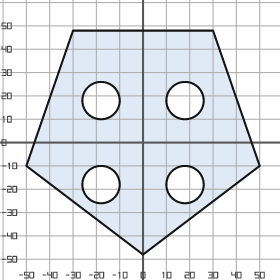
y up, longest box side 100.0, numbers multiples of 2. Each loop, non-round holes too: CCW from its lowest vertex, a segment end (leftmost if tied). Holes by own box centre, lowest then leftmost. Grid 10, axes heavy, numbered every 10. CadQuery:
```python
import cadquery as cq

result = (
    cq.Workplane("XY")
    .moveTo(0.0, -48.0)
    .lineTo(50.0, -10.0)
    .lineTo(30.0, 48.0)
    .lineTo(-30.0, 48.0)
    .lineTo(-50.0, -10.0)
    .close()
    .moveTo(-18.0, -18.0)
    .circle(8.0)
    .moveTo(18.0, -18.0)
    .circle(8.0)
    .moveTo(-18.0, 18.0)
    .circle(8.0)
    .moveTo(18.0, 18.0)
    .circle(8.0)
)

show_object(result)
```